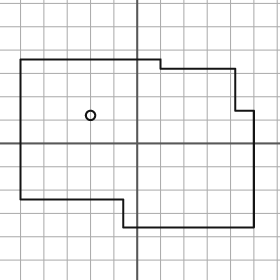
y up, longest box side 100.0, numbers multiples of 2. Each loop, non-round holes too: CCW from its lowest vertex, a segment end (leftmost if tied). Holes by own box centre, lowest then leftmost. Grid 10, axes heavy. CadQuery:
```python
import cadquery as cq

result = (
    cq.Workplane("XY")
    .moveTo(-6.0, -36.0)
    .lineTo(50.0, -36.0)
    .lineTo(50.0, 14.0)
    .lineTo(42.0, 14.0)
    .lineTo(42.0, 32.0)
    .lineTo(10.0, 32.0)
    .lineTo(10.0, 36.0)
    .lineTo(-50.0, 36.0)
    .lineTo(-50.0, -24.0)
    .lineTo(-6.0, -24.0)
    .close()
    .moveTo(-20.0, 12.0)
    .circle(2.0)
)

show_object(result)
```